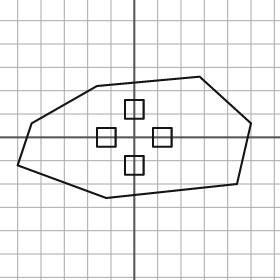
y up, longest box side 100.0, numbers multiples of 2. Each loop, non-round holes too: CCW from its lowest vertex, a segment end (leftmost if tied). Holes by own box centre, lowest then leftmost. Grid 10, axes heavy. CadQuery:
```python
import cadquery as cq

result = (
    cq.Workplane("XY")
    .moveTo(-12.0, -26.0)
    .lineTo(44.0, -20.0)
    .lineTo(50.0, 6.0)
    .lineTo(28.0, 26.0)
    .lineTo(-16.0, 22.0)
    .lineTo(-44.0, 6.0)
    .lineTo(-50.0, -12.0)
    .close()
    .moveTo(-4.0, -16.0)
    .lineTo(4.0, -16.0)
    .lineTo(4.0, -8.0)
    .lineTo(-4.0, -8.0)
    .close()
    .moveTo(-16.0, -4.0)
    .lineTo(-8.0, -4.0)
    .lineTo(-8.0, 4.0)
    .lineTo(-16.0, 4.0)
    .close()
    .moveTo(8.0, -4.0)
    .lineTo(16.0, -4.0)
    .lineTo(16.0, 4.0)
    .lineTo(8.0, 4.0)
    .close()
    .moveTo(-4.0, 8.0)
    .lineTo(4.0, 8.0)
    .lineTo(4.0, 16.0)
    .lineTo(-4.0, 16.0)
    .close()
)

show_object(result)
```